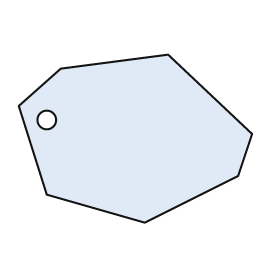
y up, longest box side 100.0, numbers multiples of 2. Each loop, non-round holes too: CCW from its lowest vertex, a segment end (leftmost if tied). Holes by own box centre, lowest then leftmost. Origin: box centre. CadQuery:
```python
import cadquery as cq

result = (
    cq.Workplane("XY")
    .moveTo(4.0, -36.0)
    .lineTo(44.0, -16.0)
    .lineTo(50.0, 2.0)
    .lineTo(14.0, 36.0)
    .lineTo(-32.0, 30.0)
    .lineTo(-50.0, 14.0)
    .lineTo(-38.0, -24.0)
    .close()
    .moveTo(-38.0, 8.0)
    .circle(4.0)
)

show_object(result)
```